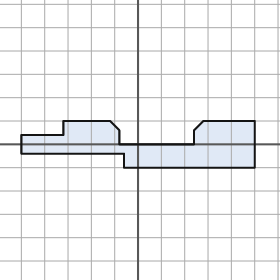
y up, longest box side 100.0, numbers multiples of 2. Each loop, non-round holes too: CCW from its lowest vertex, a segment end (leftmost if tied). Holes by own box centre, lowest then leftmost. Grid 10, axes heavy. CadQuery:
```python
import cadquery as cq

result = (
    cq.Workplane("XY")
    .moveTo(-6.0, -10.0)
    .lineTo(50.0, -10.0)
    .lineTo(50.0, 10.0)
    .lineTo(28.0, 10.0)
    .lineTo(24.0, 6.0)
    .lineTo(24.0, 0.0)
    .lineTo(-8.0, 0.0)
    .lineTo(-8.0, 6.0)
    .lineTo(-12.0, 10.0)
    .lineTo(-32.0, 10.0)
    .lineTo(-32.0, 4.0)
    .lineTo(-50.0, 4.0)
    .lineTo(-50.0, -4.0)
    .lineTo(-6.0, -4.0)
    .close()
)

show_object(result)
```